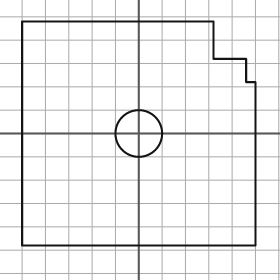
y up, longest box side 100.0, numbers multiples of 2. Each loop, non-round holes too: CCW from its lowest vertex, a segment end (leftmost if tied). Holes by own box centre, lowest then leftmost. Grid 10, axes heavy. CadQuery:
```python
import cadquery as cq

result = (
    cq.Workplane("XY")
    .moveTo(-50.0, -48.0)
    .lineTo(50.0, -48.0)
    .lineTo(50.0, 22.0)
    .lineTo(46.0, 22.0)
    .lineTo(46.0, 32.0)
    .lineTo(32.0, 32.0)
    .lineTo(32.0, 48.0)
    .lineTo(-50.0, 48.0)
    .close()
    .moveTo(0.0, 0.0)
    .circle(10.0)
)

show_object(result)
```